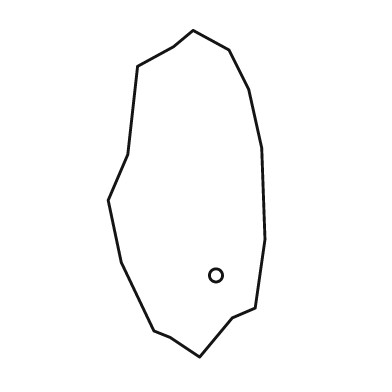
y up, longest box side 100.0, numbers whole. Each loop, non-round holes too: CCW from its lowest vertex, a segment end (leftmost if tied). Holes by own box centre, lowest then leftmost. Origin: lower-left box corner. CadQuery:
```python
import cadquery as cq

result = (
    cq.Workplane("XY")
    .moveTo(28.0, 0.0)
    .lineTo(38.0, 12.0)
    .lineTo(45.0, 15.0)
    .lineTo(48.0, 36.0)
    .lineTo(47.0, 64.0)
    .lineTo(43.0, 82.0)
    .lineTo(37.0, 94.0)
    .lineTo(26.0, 100.0)
    .lineTo(20.0, 95.0)
    .lineTo(9.0, 89.0)
    .lineTo(6.0, 62.0)
    .lineTo(0.0, 48.0)
    .lineTo(4.0, 29.0)
    .lineTo(14.0, 8.0)
    .lineTo(19.0, 6.0)
    .close()
    .moveTo(33.0, 25.0)
    .circle(2.0)
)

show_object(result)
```